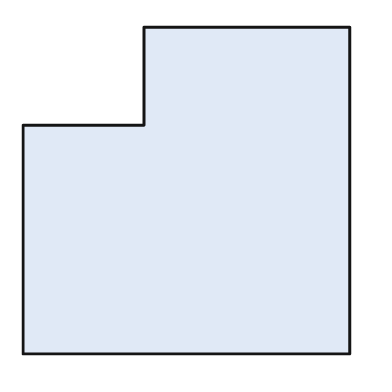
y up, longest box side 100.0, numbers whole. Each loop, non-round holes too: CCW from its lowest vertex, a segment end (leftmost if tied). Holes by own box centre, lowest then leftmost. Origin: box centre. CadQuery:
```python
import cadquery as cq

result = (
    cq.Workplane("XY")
    .moveTo(-50.0, -50.0)
    .lineTo(50.0, -50.0)
    .lineTo(50.0, 50.0)
    .lineTo(-13.0, 50.0)
    .lineTo(-13.0, 20.0)
    .lineTo(-50.0, 20.0)
    .close()
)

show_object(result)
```